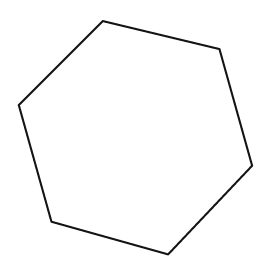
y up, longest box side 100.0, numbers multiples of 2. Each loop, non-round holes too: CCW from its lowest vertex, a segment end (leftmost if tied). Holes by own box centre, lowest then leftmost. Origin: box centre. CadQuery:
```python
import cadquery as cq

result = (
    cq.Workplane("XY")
    .moveTo(14.0, -50.0)
    .lineTo(50.0, -12.0)
    .lineTo(36.0, 38.0)
    .lineTo(-14.0, 50.0)
    .lineTo(-50.0, 14.0)
    .lineTo(-36.0, -36.0)
    .close()
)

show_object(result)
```